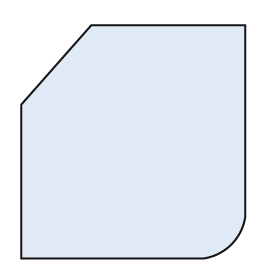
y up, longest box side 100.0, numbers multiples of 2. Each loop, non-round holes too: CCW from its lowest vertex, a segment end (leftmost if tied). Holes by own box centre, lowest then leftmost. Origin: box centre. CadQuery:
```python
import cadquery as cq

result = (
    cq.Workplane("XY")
    .moveTo(-48.0, -50.0)
    .lineTo(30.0, -50.0)
    .threePointArc((42.0, -44.0), (48.0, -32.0))
    .lineTo(48.0, 50.0)
    .lineTo(-18.0, 50.0)
    .lineTo(-48.0, 16.0)
    .close()
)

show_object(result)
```